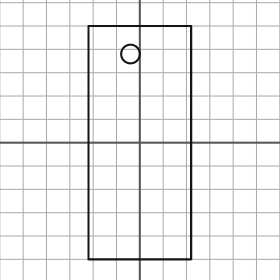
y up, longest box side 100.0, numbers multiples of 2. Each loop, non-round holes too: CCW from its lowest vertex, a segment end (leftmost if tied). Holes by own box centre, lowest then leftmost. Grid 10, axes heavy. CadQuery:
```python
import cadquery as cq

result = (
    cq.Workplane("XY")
    .moveTo(-22.0, -50.0)
    .lineTo(22.0, -50.0)
    .lineTo(22.0, 50.0)
    .lineTo(-22.0, 50.0)
    .close()
    .moveTo(-4.0, 38.0)
    .circle(4.0)
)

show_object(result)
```